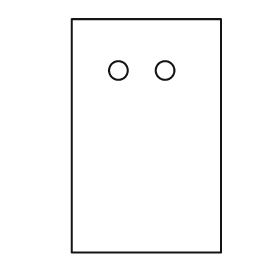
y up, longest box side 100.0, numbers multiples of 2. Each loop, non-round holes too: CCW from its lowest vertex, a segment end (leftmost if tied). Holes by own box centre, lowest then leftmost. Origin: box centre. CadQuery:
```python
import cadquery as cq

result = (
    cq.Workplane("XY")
    .moveTo(-32.0, -50.0)
    .lineTo(32.0, -50.0)
    .lineTo(32.0, 50.0)
    .lineTo(-32.0, 50.0)
    .close()
    .moveTo(-12.0, 28.0)
    .circle(4.0)
    .moveTo(8.0, 28.0)
    .circle(4.0)
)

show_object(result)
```